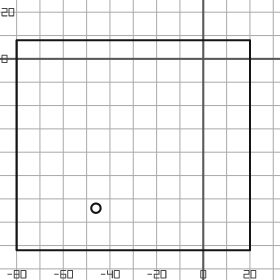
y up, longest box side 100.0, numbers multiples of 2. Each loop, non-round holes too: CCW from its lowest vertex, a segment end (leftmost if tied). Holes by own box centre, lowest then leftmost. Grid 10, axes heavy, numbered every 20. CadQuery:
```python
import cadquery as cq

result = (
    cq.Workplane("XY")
    .moveTo(-80.0, -82.0)
    .lineTo(20.0, -82.0)
    .lineTo(20.0, 8.0)
    .lineTo(-80.0, 8.0)
    .close()
    .moveTo(-46.0, -64.0)
    .circle(2.0)
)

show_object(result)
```